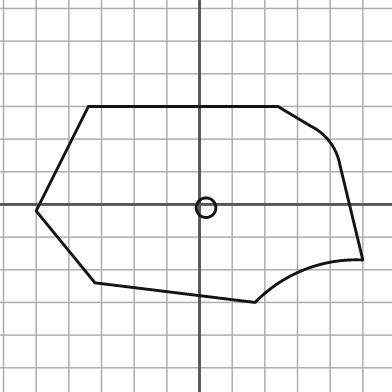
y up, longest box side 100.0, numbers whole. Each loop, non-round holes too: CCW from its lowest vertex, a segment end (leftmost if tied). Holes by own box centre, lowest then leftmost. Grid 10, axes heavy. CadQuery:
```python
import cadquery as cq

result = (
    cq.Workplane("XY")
    .moveTo(17.0, -30.0)
    .threePointArc((32.0, -20.0), (50.0, -17.0))
    .lineTo(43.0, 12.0)
    .threePointArc((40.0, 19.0), (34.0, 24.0))
    .lineTo(24.0, 30.0)
    .lineTo(-34.0, 30.0)
    .lineTo(-50.0, -2.0)
    .lineTo(-32.0, -24.0)
    .close()
    .moveTo(2.0, -1.0)
    .circle(3.0)
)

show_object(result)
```